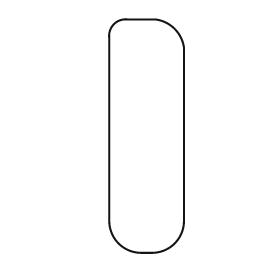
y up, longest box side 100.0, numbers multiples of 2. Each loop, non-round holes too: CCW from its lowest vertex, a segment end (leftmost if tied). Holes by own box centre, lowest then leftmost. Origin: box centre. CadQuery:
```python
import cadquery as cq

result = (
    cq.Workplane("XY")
    .moveTo(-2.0, -50.0)
    .lineTo(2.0, -50.0)
    .threePointArc((12.0, -46.0), (16.0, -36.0))
    .lineTo(16.0, 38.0)
    .threePointArc((12.0, 46.0), (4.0, 50.0))
    .lineTo(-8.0, 50.0)
    .threePointArc((-14.0, 48.0), (-16.0, 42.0))
    .lineTo(-16.0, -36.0)
    .threePointArc((-12.0, -46.0), (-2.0, -50.0))
    .close()
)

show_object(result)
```